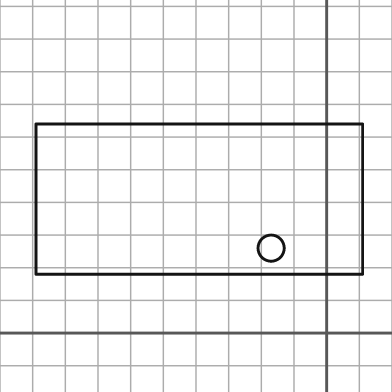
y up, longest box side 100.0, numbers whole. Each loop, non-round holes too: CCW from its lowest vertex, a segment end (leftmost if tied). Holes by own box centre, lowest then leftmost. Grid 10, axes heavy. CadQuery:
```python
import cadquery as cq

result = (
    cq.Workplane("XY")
    .moveTo(-89.0, 18.0)
    .lineTo(11.0, 18.0)
    .lineTo(11.0, 64.0)
    .lineTo(-89.0, 64.0)
    .close()
    .moveTo(-17.0, 26.0)
    .circle(4.0)
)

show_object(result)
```